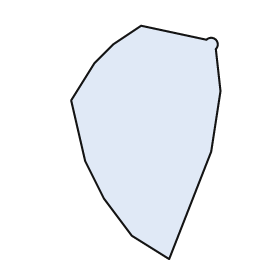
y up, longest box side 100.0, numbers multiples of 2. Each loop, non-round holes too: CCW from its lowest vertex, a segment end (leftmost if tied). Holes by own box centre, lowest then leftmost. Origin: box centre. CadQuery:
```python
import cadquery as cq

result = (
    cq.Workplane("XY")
    .moveTo(10.0, -50.0)
    .lineTo(28.0, -4.0)
    .lineTo(32.0, 22.0)
    .lineTo(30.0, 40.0)
    .threePointArc((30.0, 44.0), (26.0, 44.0))
    .lineTo(-2.0, 50.0)
    .lineTo(-14.0, 42.0)
    .lineTo(-22.0, 34.0)
    .lineTo(-32.0, 18.0)
    .lineTo(-26.0, -8.0)
    .lineTo(-18.0, -24.0)
    .lineTo(-6.0, -40.0)
    .close()
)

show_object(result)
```